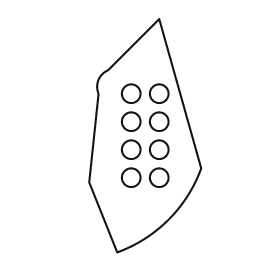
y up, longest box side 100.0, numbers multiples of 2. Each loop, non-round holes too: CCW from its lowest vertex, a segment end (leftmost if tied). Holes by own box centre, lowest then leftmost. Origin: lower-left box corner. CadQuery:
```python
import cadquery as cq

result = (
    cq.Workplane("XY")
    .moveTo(12.0, 0.0)
    .threePointArc((34.0, 14.0), (48.0, 36.0))
    .lineTo(30.0, 100.0)
    .lineTo(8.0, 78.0)
    .threePointArc((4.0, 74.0), (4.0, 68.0))
    .lineTo(0.0, 30.0)
    .close()
    .moveTo(18.0, 32.0)
    .circle(4.0)
    .moveTo(30.0, 32.0)
    .circle(4.0)
    .moveTo(18.0, 44.0)
    .circle(4.0)
    .moveTo(30.0, 44.0)
    .circle(4.0)
    .moveTo(18.0, 56.0)
    .circle(4.0)
    .moveTo(30.0, 56.0)
    .circle(4.0)
    .moveTo(18.0, 68.0)
    .circle(4.0)
    .moveTo(30.0, 68.0)
    .circle(4.0)
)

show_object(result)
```